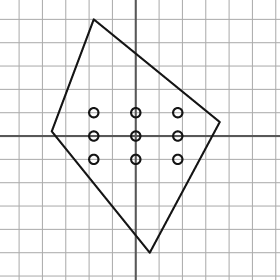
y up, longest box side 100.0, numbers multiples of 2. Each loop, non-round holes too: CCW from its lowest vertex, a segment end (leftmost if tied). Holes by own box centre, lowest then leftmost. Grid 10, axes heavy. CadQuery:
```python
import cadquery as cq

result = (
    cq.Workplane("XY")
    .moveTo(6.0, -50.0)
    .lineTo(36.0, 6.0)
    .lineTo(-18.0, 50.0)
    .lineTo(-36.0, 2.0)
    .close()
    .moveTo(-18.0, -10.0)
    .circle(2.0)
    .moveTo(0.0, -10.0)
    .circle(2.0)
    .moveTo(18.0, -10.0)
    .circle(2.0)
    .moveTo(-18.0, 0.0)
    .circle(2.0)
    .moveTo(0.0, 0.0)
    .circle(2.0)
    .moveTo(18.0, 0.0)
    .circle(2.0)
    .moveTo(-18.0, 10.0)
    .circle(2.0)
    .moveTo(0.0, 10.0)
    .circle(2.0)
    .moveTo(18.0, 10.0)
    .circle(2.0)
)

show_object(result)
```